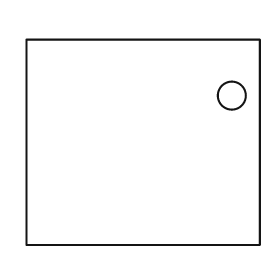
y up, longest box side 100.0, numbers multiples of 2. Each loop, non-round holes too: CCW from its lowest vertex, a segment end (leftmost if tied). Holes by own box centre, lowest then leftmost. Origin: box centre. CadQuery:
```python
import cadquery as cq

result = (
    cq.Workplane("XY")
    .moveTo(-50.0, -44.0)
    .lineTo(50.0, -44.0)
    .lineTo(50.0, 44.0)
    .lineTo(-50.0, 44.0)
    .close()
    .moveTo(38.0, 20.0)
    .circle(6.0)
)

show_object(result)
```